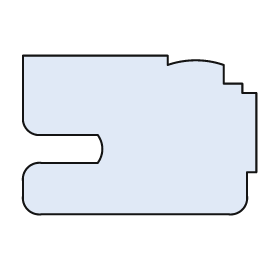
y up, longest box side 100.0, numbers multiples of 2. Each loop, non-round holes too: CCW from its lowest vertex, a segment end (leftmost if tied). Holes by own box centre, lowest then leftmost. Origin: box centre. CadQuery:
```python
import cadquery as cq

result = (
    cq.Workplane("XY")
    .moveTo(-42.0, -34.0)
    .lineTo(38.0, -34.0)
    .threePointArc((44.0, -32.0), (46.0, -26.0))
    .lineTo(46.0, -16.0)
    .lineTo(50.0, -16.0)
    .lineTo(50.0, 18.0)
    .lineTo(44.0, 18.0)
    .lineTo(44.0, 22.0)
    .lineTo(36.0, 22.0)
    .lineTo(36.0, 30.0)
    .threePointArc((24.0, 32.0), (12.0, 30.0))
    .lineTo(12.0, 34.0)
    .lineTo(-50.0, 34.0)
    .lineTo(-50.0, 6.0)
    .threePointArc((-48.0, 2.0), (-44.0, 0.0))
    .lineTo(-18.0, 0.0)
    .threePointArc((-16.0, -6.0), (-18.0, -12.0))
    .lineTo(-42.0, -12.0)
    .threePointArc((-48.0, -14.0), (-50.0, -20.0))
    .lineTo(-50.0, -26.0)
    .threePointArc((-48.0, -32.0), (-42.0, -34.0))
    .close()
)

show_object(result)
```